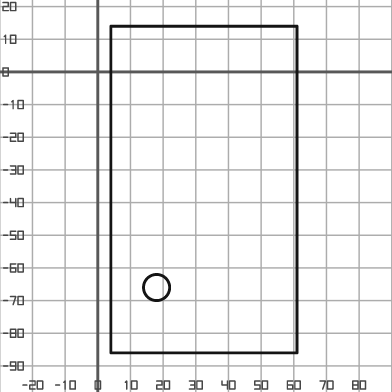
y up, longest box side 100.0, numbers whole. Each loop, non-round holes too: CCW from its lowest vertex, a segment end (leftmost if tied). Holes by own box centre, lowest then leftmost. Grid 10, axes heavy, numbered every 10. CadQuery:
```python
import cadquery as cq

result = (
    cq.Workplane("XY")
    .moveTo(4.0, -86.0)
    .lineTo(61.0, -86.0)
    .lineTo(61.0, 14.0)
    .lineTo(4.0, 14.0)
    .close()
    .moveTo(18.0, -66.0)
    .circle(4.0)
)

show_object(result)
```